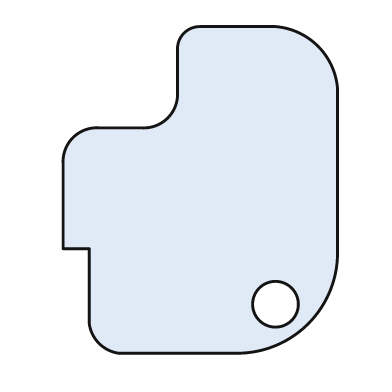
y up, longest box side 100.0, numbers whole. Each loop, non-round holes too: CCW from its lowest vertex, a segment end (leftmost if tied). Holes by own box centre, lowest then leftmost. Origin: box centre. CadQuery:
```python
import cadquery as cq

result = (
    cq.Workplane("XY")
    .moveTo(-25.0, -50.0)
    .lineTo(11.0, -50.0)
    .threePointArc((33.0, -41.0), (42.0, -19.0))
    .lineTo(42.0, 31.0)
    .threePointArc((36.0, 44.0), (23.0, 50.0))
    .lineTo(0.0, 50.0)
    .threePointArc((-5.0, 48.0), (-7.0, 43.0))
    .lineTo(-7.0, 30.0)
    .threePointArc((-10.0, 22.0), (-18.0, 19.0))
    .lineTo(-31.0, 19.0)
    .threePointArc((-39.0, 16.0), (-42.0, 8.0))
    .lineTo(-42.0, -18.0)
    .lineTo(-34.0, -18.0)
    .lineTo(-34.0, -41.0)
    .threePointArc((-31.0, -47.0), (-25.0, -50.0))
    .close()
    .moveTo(23.0, -35.0)
    .circle(7.0)
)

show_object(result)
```